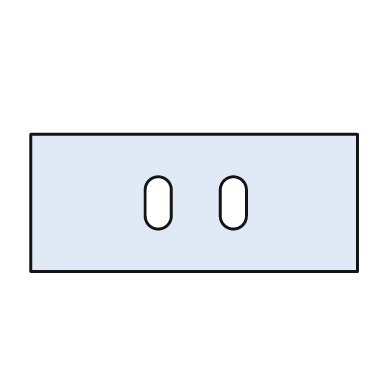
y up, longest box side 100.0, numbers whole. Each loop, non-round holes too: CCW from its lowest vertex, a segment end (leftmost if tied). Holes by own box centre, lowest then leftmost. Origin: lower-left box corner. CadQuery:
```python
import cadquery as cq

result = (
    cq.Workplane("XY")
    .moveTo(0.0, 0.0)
    .lineTo(100.0, 0.0)
    .lineTo(100.0, 42.0)
    .lineTo(0.0, 42.0)
    .close()
    .moveTo(35.0, 17.0)
    .threePointArc((39.0, 13.0), (43.0, 17.0))
    .lineTo(43.0, 25.0)
    .threePointArc((39.0, 29.0), (35.0, 25.0))
    .close()
    .moveTo(58.0, 17.0)
    .threePointArc((62.0, 13.0), (66.0, 17.0))
    .lineTo(66.0, 25.0)
    .threePointArc((62.0, 29.0), (58.0, 25.0))
    .close()
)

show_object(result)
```